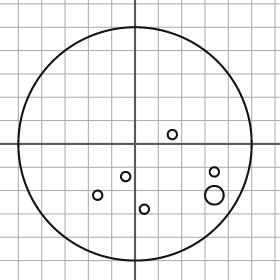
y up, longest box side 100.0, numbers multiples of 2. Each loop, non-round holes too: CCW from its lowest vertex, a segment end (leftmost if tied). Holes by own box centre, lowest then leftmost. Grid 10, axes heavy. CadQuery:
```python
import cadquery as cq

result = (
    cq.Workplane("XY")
    .moveTo(0.0, 0.0)
    .circle(50.0)
    .moveTo(4.0, -28.0)
    .circle(2.0)
    .moveTo(-16.0, -22.0)
    .circle(2.0)
    .moveTo(34.0, -22.0)
    .circle(4.0)
    .moveTo(-4.0, -14.0)
    .circle(2.0)
    .moveTo(34.0, -12.0)
    .circle(2.0)
    .moveTo(16.0, 4.0)
    .circle(2.0)
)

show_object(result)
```